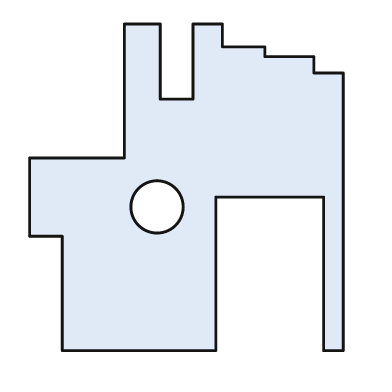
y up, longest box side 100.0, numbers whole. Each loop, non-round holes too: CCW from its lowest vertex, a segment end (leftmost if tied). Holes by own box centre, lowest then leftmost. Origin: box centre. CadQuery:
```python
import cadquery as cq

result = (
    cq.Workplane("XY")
    .moveTo(-38.0, -50.0)
    .lineTo(9.0, -50.0)
    .lineTo(9.0, -3.0)
    .lineTo(42.0, -3.0)
    .lineTo(42.0, -50.0)
    .lineTo(48.0, -50.0)
    .lineTo(48.0, 35.0)
    .lineTo(39.0, 35.0)
    .lineTo(39.0, 40.0)
    .lineTo(24.0, 40.0)
    .lineTo(24.0, 43.0)
    .lineTo(11.0, 43.0)
    .lineTo(11.0, 50.0)
    .lineTo(2.0, 50.0)
    .lineTo(2.0, 27.0)
    .lineTo(-8.0, 27.0)
    .lineTo(-8.0, 50.0)
    .lineTo(-19.0, 50.0)
    .lineTo(-19.0, 9.0)
    .lineTo(-48.0, 9.0)
    .lineTo(-48.0, -15.0)
    .lineTo(-38.0, -15.0)
    .close()
    .moveTo(-9.0, -6.0)
    .circle(8.0)
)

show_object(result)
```